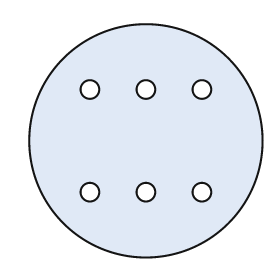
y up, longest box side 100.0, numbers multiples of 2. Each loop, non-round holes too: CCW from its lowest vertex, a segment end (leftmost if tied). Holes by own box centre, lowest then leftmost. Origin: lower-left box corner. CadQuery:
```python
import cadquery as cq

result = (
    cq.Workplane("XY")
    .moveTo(50.0, 50.0)
    .circle(50.0)
    .moveTo(26.0, 28.0)
    .circle(4.0)
    .moveTo(50.0, 28.0)
    .circle(4.0)
    .moveTo(74.0, 28.0)
    .circle(4.0)
    .moveTo(26.0, 72.0)
    .circle(4.0)
    .moveTo(50.0, 72.0)
    .circle(4.0)
    .moveTo(74.0, 72.0)
    .circle(4.0)
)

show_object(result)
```